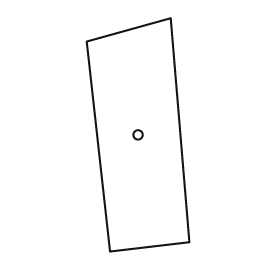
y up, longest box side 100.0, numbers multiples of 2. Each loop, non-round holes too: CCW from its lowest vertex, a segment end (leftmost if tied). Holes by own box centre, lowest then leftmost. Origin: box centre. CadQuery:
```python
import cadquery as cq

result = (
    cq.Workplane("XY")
    .moveTo(-12.0, -50.0)
    .lineTo(22.0, -46.0)
    .lineTo(14.0, 50.0)
    .lineTo(-22.0, 40.0)
    .close()
    .moveTo(0.0, 0.0)
    .circle(2.0)
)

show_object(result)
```